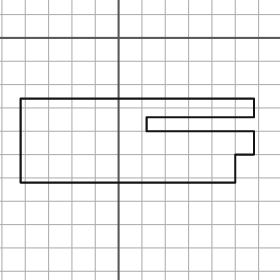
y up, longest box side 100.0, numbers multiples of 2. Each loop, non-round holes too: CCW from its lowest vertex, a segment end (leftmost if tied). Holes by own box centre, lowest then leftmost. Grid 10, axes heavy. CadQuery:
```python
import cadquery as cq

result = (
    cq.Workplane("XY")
    .moveTo(-42.0, -62.0)
    .lineTo(50.0, -62.0)
    .lineTo(50.0, -50.0)
    .lineTo(58.0, -50.0)
    .lineTo(58.0, -40.0)
    .lineTo(12.0, -40.0)
    .lineTo(12.0, -34.0)
    .lineTo(58.0, -34.0)
    .lineTo(58.0, -26.0)
    .lineTo(-42.0, -26.0)
    .close()
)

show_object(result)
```